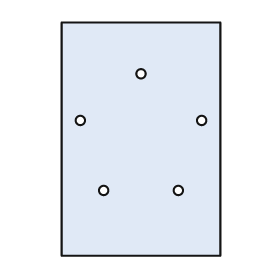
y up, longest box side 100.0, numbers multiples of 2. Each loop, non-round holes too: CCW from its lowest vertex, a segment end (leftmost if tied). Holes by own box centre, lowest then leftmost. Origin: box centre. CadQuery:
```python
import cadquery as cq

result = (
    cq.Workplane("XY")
    .moveTo(-34.0, -50.0)
    .lineTo(34.0, -50.0)
    .lineTo(34.0, 50.0)
    .lineTo(-34.0, 50.0)
    .close()
    .moveTo(-16.0, -22.0)
    .circle(2.0)
    .moveTo(16.0, -22.0)
    .circle(2.0)
    .moveTo(-26.0, 8.0)
    .circle(2.0)
    .moveTo(26.0, 8.0)
    .circle(2.0)
    .moveTo(0.0, 28.0)
    .circle(2.0)
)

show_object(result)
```